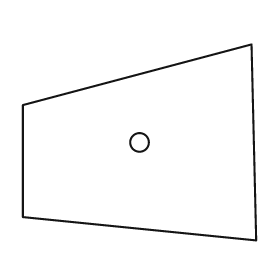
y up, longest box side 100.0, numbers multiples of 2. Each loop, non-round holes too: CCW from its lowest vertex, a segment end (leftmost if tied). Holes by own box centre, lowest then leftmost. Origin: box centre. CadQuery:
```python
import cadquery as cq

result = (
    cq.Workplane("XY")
    .moveTo(50.0, -42.0)
    .lineTo(48.0, 42.0)
    .lineTo(-50.0, 16.0)
    .lineTo(-50.0, -32.0)
    .close()
    .moveTo(0.0, 0.0)
    .circle(4.0)
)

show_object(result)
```